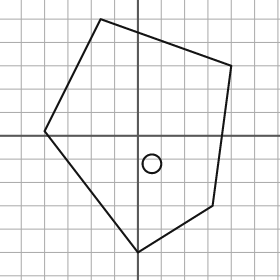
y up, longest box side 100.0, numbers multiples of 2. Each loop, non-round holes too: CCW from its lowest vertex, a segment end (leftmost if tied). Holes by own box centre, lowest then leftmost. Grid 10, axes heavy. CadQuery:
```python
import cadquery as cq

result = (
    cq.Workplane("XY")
    .moveTo(0.0, -50.0)
    .lineTo(32.0, -30.0)
    .lineTo(40.0, 30.0)
    .lineTo(-16.0, 50.0)
    .lineTo(-40.0, 2.0)
    .close()
    .moveTo(6.0, -12.0)
    .circle(4.0)
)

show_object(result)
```